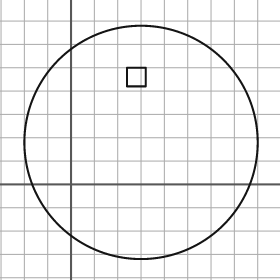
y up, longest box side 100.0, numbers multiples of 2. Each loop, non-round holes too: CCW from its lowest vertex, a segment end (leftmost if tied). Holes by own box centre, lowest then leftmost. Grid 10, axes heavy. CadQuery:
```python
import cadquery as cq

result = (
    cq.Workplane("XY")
    .moveTo(30.0, 18.0)
    .circle(50.0)
    .moveTo(24.0, 42.0)
    .lineTo(32.0, 42.0)
    .lineTo(32.0, 50.0)
    .lineTo(24.0, 50.0)
    .close()
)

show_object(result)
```